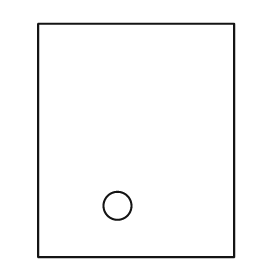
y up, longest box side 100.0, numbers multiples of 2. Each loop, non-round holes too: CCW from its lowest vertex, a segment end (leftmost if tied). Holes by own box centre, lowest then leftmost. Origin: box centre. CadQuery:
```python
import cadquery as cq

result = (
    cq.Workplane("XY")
    .moveTo(-42.0, -50.0)
    .lineTo(42.0, -50.0)
    .lineTo(42.0, 50.0)
    .lineTo(-42.0, 50.0)
    .close()
    .moveTo(-8.0, -28.0)
    .circle(6.0)
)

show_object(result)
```